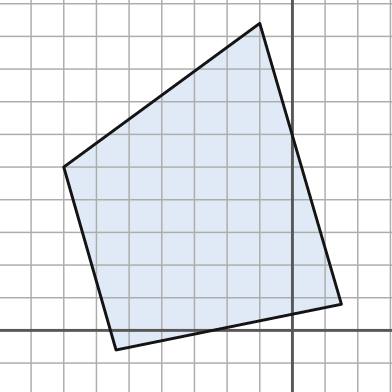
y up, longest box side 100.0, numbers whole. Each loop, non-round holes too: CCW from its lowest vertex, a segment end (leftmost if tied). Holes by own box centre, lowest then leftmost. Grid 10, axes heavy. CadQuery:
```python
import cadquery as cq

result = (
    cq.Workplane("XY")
    .moveTo(-54.0, -6.0)
    .lineTo(15.0, 8.0)
    .lineTo(-10.0, 94.0)
    .lineTo(-70.0, 50.0)
    .close()
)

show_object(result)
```